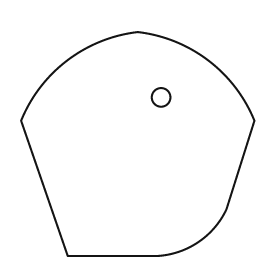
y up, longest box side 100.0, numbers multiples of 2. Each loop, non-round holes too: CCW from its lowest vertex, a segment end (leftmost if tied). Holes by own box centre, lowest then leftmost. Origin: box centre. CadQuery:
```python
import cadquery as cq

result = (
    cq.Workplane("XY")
    .moveTo(-30.0, -48.0)
    .lineTo(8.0, -48.0)
    .threePointArc((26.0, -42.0), (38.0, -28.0))
    .lineTo(50.0, 10.0)
    .threePointArc((30.0, 36.0), (0.0, 48.0))
    .threePointArc((-30.0, 36.0), (-50.0, 10.0))
    .close()
    .moveTo(10.0, 20.0)
    .circle(4.0)
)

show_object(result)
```